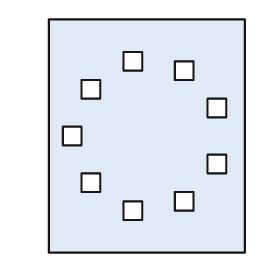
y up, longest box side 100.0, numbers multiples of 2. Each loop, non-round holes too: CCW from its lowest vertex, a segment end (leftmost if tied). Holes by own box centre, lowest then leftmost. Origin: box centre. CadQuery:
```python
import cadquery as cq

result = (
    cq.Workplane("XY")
    .moveTo(-42.0, -50.0)
    .lineTo(42.0, -50.0)
    .lineTo(42.0, 50.0)
    .lineTo(-42.0, 50.0)
    .close()
    .moveTo(-10.0, -36.0)
    .lineTo(-2.0, -36.0)
    .lineTo(-2.0, -28.0)
    .lineTo(-10.0, -28.0)
    .close()
    .moveTo(12.0, -32.0)
    .lineTo(20.0, -32.0)
    .lineTo(20.0, -24.0)
    .lineTo(12.0, -24.0)
    .close()
    .moveTo(-28.0, -24.0)
    .lineTo(-20.0, -24.0)
    .lineTo(-20.0, -16.0)
    .lineTo(-28.0, -16.0)
    .close()
    .moveTo(26.0, -16.0)
    .lineTo(34.0, -16.0)
    .lineTo(34.0, -8.0)
    .lineTo(26.0, -8.0)
    .close()
    .moveTo(-36.0, -4.0)
    .lineTo(-28.0, -4.0)
    .lineTo(-28.0, 4.0)
    .lineTo(-36.0, 4.0)
    .close()
    .moveTo(26.0, 8.0)
    .lineTo(34.0, 8.0)
    .lineTo(34.0, 16.0)
    .lineTo(26.0, 16.0)
    .close()
    .moveTo(-28.0, 16.0)
    .lineTo(-20.0, 16.0)
    .lineTo(-20.0, 24.0)
    .lineTo(-28.0, 24.0)
    .close()
    .moveTo(12.0, 24.0)
    .lineTo(20.0, 24.0)
    .lineTo(20.0, 32.0)
    .lineTo(12.0, 32.0)
    .close()
    .moveTo(-10.0, 28.0)
    .lineTo(-2.0, 28.0)
    .lineTo(-2.0, 36.0)
    .lineTo(-10.0, 36.0)
    .close()
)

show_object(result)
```